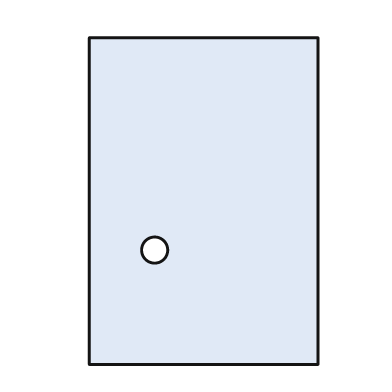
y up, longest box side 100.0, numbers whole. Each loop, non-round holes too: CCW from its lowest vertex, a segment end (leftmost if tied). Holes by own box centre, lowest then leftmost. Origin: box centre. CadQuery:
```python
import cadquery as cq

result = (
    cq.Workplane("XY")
    .moveTo(-35.0, -50.0)
    .lineTo(35.0, -50.0)
    .lineTo(35.0, 50.0)
    .lineTo(-35.0, 50.0)
    .close()
    .moveTo(-15.0, -15.0)
    .circle(4.0)
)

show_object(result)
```